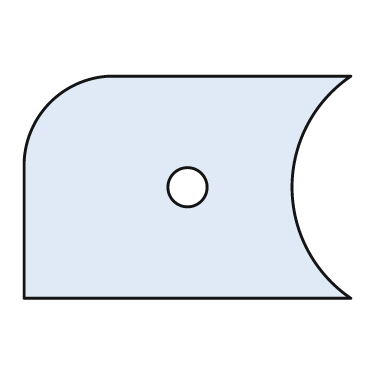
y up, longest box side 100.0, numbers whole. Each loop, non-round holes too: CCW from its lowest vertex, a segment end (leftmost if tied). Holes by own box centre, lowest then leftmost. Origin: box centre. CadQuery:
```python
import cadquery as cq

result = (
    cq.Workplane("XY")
    .moveTo(-50.0, -34.0)
    .lineTo(50.0, -34.0)
    .threePointArc((32.0, 0.0), (50.0, 34.0))
    .lineTo(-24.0, 34.0)
    .threePointArc((-42.0, 26.0), (-50.0, 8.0))
    .close()
    .moveTo(0.0, 0.0)
    .circle(6.0)
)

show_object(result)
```